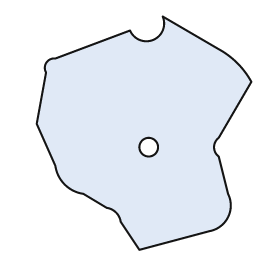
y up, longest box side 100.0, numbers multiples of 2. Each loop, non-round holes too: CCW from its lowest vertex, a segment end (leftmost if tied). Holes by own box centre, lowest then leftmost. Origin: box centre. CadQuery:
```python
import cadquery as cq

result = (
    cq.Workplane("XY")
    .moveTo(-2.0, -50.0)
    .lineTo(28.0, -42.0)
    .threePointArc((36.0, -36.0), (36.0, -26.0))
    .lineTo(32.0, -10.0)
    .threePointArc((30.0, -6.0), (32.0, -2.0))
    .lineTo(46.0, 22.0)
    .threePointArc((40.0, 30.0), (32.0, 36.0))
    .lineTo(8.0, 50.0)
    .threePointArc((4.0, 40.0), (-6.0, 44.0))
    .lineTo(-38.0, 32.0)
    .threePointArc((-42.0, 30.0), (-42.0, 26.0))
    .lineTo(-46.0, 4.0)
    .lineTo(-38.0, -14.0)
    .threePointArc((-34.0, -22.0), (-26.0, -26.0))
    .lineTo(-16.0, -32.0)
    .threePointArc((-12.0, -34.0), (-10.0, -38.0))
    .close()
    .moveTo(2.0, -6.0)
    .circle(4.0)
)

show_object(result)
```